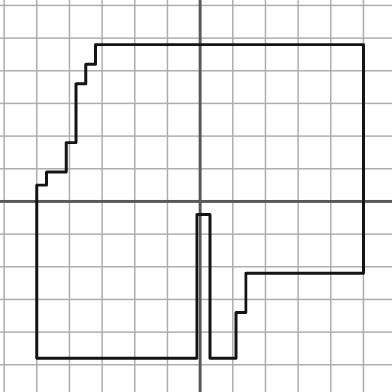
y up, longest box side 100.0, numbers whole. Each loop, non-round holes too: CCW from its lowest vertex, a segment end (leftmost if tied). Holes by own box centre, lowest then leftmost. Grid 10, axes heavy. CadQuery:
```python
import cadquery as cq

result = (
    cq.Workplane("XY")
    .moveTo(-50.0, -48.0)
    .lineTo(-1.0, -48.0)
    .lineTo(-1.0, -4.0)
    .lineTo(3.0, -4.0)
    .lineTo(3.0, -48.0)
    .lineTo(11.0, -48.0)
    .lineTo(11.0, -34.0)
    .lineTo(14.0, -34.0)
    .lineTo(14.0, -22.0)
    .lineTo(50.0, -22.0)
    .lineTo(50.0, 48.0)
    .lineTo(-32.0, 48.0)
    .lineTo(-32.0, 42.0)
    .lineTo(-35.0, 42.0)
    .lineTo(-35.0, 36.0)
    .lineTo(-38.0, 36.0)
    .lineTo(-38.0, 18.0)
    .lineTo(-41.0, 18.0)
    .lineTo(-41.0, 9.0)
    .lineTo(-47.0, 9.0)
    .lineTo(-47.0, 5.0)
    .lineTo(-50.0, 5.0)
    .close()
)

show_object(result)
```